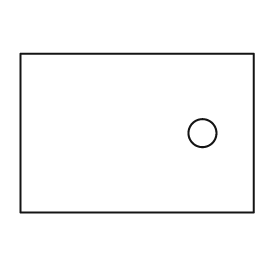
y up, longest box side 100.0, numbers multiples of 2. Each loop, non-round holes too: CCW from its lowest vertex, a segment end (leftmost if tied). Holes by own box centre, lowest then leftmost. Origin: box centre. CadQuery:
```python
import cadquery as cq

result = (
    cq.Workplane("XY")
    .moveTo(-50.0, -34.0)
    .lineTo(50.0, -34.0)
    .lineTo(50.0, 34.0)
    .lineTo(-50.0, 34.0)
    .close()
    .moveTo(28.0, 0.0)
    .circle(6.0)
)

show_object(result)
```